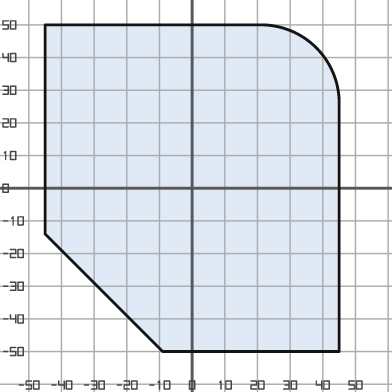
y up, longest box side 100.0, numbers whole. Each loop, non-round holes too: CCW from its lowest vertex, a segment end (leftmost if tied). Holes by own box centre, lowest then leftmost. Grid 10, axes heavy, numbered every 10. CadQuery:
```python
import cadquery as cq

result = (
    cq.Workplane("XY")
    .moveTo(-9.0, -50.0)
    .lineTo(45.0, -50.0)
    .lineTo(45.0, 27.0)
    .threePointArc((38.0, 43.0), (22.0, 50.0))
    .lineTo(-45.0, 50.0)
    .lineTo(-45.0, -14.0)
    .close()
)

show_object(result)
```